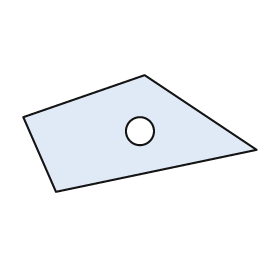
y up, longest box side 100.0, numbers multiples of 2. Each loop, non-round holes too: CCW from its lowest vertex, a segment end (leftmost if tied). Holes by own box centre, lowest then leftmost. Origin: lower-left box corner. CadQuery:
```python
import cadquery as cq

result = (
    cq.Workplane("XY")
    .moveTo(14.0, 0.0)
    .lineTo(100.0, 18.0)
    .lineTo(52.0, 50.0)
    .lineTo(0.0, 32.0)
    .close()
    .moveTo(50.0, 26.0)
    .circle(6.0)
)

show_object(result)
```